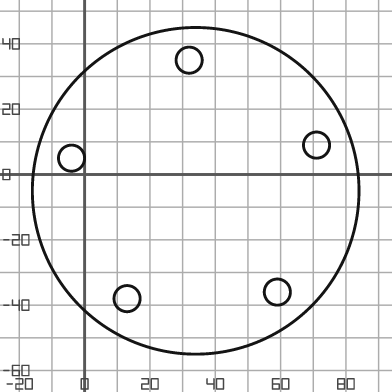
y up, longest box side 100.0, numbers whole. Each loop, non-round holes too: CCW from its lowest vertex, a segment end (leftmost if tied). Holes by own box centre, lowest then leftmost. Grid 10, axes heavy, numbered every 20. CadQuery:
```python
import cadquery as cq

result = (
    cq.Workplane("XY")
    .moveTo(34.0, -5.0)
    .circle(50.0)
    .moveTo(13.0, -38.0)
    .circle(4.0)
    .moveTo(59.0, -36.0)
    .circle(4.0)
    .moveTo(-4.0, 5.0)
    .circle(4.0)
    .moveTo(71.0, 9.0)
    .circle(4.0)
    .moveTo(32.0, 35.0)
    .circle(4.0)
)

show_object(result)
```